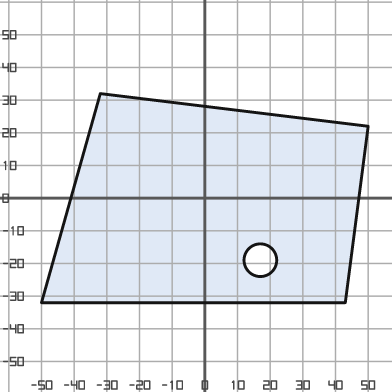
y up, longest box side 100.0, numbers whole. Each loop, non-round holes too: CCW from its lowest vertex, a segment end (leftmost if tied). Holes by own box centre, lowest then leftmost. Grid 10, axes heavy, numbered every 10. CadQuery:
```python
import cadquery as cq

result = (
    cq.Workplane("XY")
    .moveTo(-50.0, -32.0)
    .lineTo(43.0, -32.0)
    .lineTo(50.0, 22.0)
    .lineTo(-32.0, 32.0)
    .close()
    .moveTo(17.0, -19.0)
    .circle(5.0)
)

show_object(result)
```